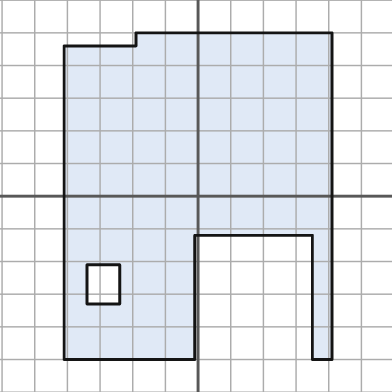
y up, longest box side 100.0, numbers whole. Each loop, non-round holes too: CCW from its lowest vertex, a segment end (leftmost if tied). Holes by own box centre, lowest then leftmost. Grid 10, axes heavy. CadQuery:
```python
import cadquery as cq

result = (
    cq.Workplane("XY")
    .moveTo(-41.0, -50.0)
    .lineTo(-1.0, -50.0)
    .lineTo(-1.0, -12.0)
    .lineTo(35.0, -12.0)
    .lineTo(35.0, -50.0)
    .lineTo(41.0, -50.0)
    .lineTo(41.0, 50.0)
    .lineTo(-19.0, 50.0)
    .lineTo(-19.0, 46.0)
    .lineTo(-41.0, 46.0)
    .close()
    .moveTo(-34.0, -33.0)
    .lineTo(-24.0, -33.0)
    .lineTo(-24.0, -21.0)
    .lineTo(-34.0, -21.0)
    .close()
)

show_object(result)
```